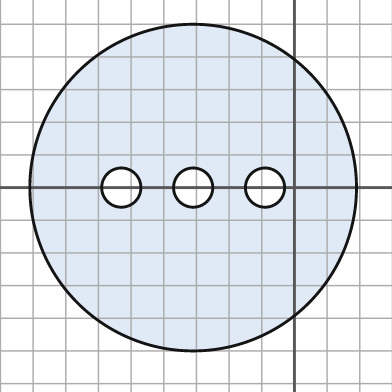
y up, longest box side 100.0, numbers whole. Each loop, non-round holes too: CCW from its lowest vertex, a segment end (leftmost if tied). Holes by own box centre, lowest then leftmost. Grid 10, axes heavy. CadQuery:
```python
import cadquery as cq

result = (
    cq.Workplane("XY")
    .moveTo(-31.0, 0.0)
    .circle(50.0)
    .moveTo(-53.0, 0.0)
    .circle(6.0)
    .moveTo(-31.0, 0.0)
    .circle(6.0)
    .moveTo(-9.0, 0.0)
    .circle(6.0)
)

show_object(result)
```